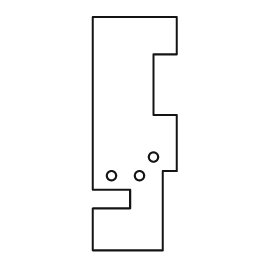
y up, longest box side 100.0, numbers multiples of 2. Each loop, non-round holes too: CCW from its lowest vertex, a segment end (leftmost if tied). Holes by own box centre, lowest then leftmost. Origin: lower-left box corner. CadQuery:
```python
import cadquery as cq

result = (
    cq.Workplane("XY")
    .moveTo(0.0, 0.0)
    .lineTo(30.0, 0.0)
    .lineTo(30.0, 34.0)
    .lineTo(36.0, 34.0)
    .lineTo(36.0, 58.0)
    .lineTo(26.0, 58.0)
    .lineTo(26.0, 84.0)
    .lineTo(36.0, 84.0)
    .lineTo(36.0, 100.0)
    .lineTo(0.0, 100.0)
    .lineTo(0.0, 26.0)
    .lineTo(16.0, 26.0)
    .lineTo(16.0, 18.0)
    .lineTo(0.0, 18.0)
    .close()
    .moveTo(8.0, 32.0)
    .circle(2.0)
    .moveTo(20.0, 32.0)
    .circle(2.0)
    .moveTo(26.0, 40.0)
    .circle(2.0)
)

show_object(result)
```